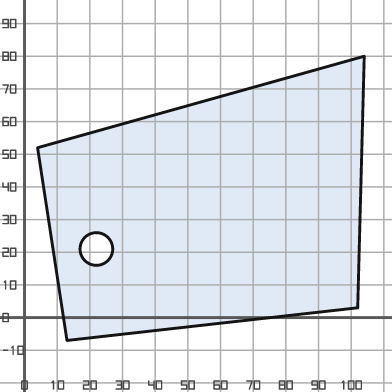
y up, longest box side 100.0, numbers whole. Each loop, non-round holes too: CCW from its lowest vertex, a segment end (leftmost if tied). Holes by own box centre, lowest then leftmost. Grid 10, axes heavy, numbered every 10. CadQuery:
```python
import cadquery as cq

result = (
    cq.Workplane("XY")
    .moveTo(13.0, -7.0)
    .lineTo(102.0, 3.0)
    .lineTo(104.0, 80.0)
    .lineTo(4.0, 52.0)
    .close()
    .moveTo(22.0, 21.0)
    .circle(5.0)
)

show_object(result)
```